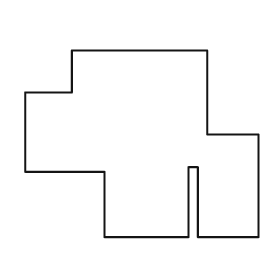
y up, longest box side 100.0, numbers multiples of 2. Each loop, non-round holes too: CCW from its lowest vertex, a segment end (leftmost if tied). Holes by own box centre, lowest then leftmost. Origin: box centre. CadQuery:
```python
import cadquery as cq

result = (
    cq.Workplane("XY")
    .moveTo(-16.0, -40.0)
    .lineTo(20.0, -40.0)
    .lineTo(20.0, -10.0)
    .lineTo(24.0, -10.0)
    .lineTo(24.0, -40.0)
    .lineTo(50.0, -40.0)
    .lineTo(50.0, 4.0)
    .lineTo(28.0, 4.0)
    .lineTo(28.0, 40.0)
    .lineTo(-30.0, 40.0)
    .lineTo(-30.0, 22.0)
    .lineTo(-50.0, 22.0)
    .lineTo(-50.0, -12.0)
    .lineTo(-16.0, -12.0)
    .close()
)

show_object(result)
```